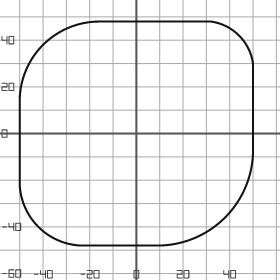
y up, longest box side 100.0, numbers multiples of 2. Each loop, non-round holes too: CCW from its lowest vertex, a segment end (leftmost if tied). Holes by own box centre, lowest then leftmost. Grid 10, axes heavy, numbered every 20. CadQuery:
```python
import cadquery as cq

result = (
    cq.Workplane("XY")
    .moveTo(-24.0, -48.0)
    .lineTo(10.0, -48.0)
    .threePointArc((38.0, -36.0), (50.0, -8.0))
    .lineTo(50.0, 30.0)
    .threePointArc((44.0, 42.0), (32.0, 48.0))
    .lineTo(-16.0, 48.0)
    .threePointArc((-40.0, 38.0), (-50.0, 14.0))
    .lineTo(-50.0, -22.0)
    .threePointArc((-42.0, -40.0), (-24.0, -48.0))
    .close()
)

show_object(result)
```